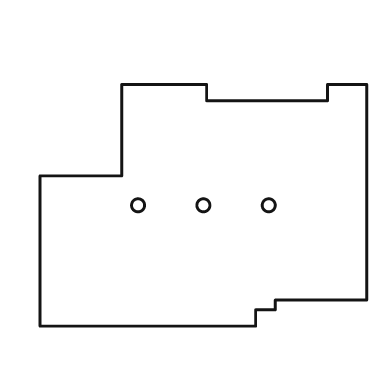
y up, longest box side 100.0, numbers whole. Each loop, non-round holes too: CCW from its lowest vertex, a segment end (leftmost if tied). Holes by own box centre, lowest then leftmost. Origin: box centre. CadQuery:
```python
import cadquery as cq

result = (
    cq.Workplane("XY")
    .moveTo(-50.0, -37.0)
    .lineTo(16.0, -37.0)
    .lineTo(16.0, -32.0)
    .lineTo(22.0, -32.0)
    .lineTo(22.0, -29.0)
    .lineTo(50.0, -29.0)
    .lineTo(50.0, 37.0)
    .lineTo(38.0, 37.0)
    .lineTo(38.0, 32.0)
    .lineTo(1.0, 32.0)
    .lineTo(1.0, 37.0)
    .lineTo(-25.0, 37.0)
    .lineTo(-25.0, 9.0)
    .lineTo(-50.0, 9.0)
    .close()
    .moveTo(-20.0, 0.0)
    .circle(2.0)
    .moveTo(0.0, 0.0)
    .circle(2.0)
    .moveTo(20.0, 0.0)
    .circle(2.0)
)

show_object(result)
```